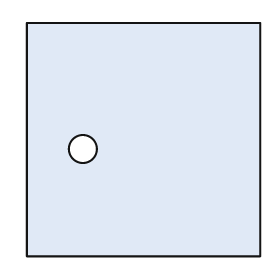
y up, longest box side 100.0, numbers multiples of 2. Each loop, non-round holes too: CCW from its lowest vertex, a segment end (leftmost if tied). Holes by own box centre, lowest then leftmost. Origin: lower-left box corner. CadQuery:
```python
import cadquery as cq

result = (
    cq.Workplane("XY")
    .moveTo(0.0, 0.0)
    .lineTo(100.0, 0.0)
    .lineTo(100.0, 100.0)
    .lineTo(0.0, 100.0)
    .close()
    .moveTo(24.0, 46.0)
    .circle(6.0)
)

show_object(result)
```